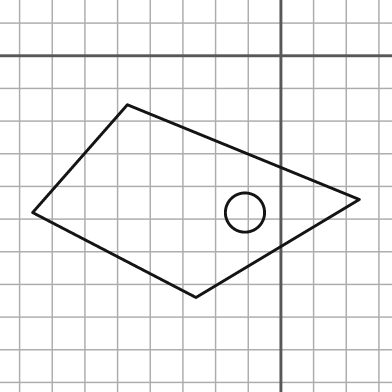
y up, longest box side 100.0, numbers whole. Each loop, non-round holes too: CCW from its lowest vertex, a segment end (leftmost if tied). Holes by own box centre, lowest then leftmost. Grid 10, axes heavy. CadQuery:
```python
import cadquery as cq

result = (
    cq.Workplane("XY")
    .moveTo(-26.0, -74.0)
    .lineTo(24.0, -44.0)
    .lineTo(-47.0, -15.0)
    .lineTo(-76.0, -48.0)
    .close()
    .moveTo(-11.0, -48.0)
    .circle(6.0)
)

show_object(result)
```